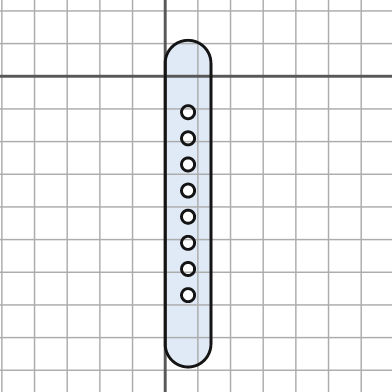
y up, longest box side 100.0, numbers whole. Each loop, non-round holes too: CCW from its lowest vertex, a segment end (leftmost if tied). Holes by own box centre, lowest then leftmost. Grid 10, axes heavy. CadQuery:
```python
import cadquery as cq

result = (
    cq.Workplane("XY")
    .moveTo(0.0, -82.0)
    .threePointArc((7.0, -89.0), (14.0, -82.0))
    .lineTo(14.0, 4.0)
    .threePointArc((7.0, 11.0), (0.0, 4.0))
    .close()
    .moveTo(7.0, -67.0)
    .circle(2.0)
    .moveTo(7.0, -59.0)
    .circle(2.0)
    .moveTo(7.0, -51.0)
    .circle(2.0)
    .moveTo(7.0, -43.0)
    .circle(2.0)
    .moveTo(7.0, -35.0)
    .circle(2.0)
    .moveTo(7.0, -27.0)
    .circle(2.0)
    .moveTo(7.0, -19.0)
    .circle(2.0)
    .moveTo(7.0, -11.0)
    .circle(2.0)
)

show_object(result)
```